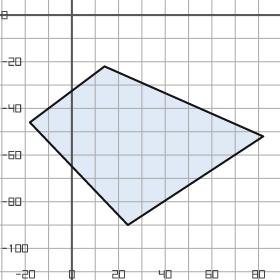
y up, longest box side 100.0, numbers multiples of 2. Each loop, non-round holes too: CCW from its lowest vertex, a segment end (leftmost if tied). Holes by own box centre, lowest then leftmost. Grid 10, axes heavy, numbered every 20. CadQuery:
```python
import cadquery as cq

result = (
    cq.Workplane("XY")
    .moveTo(24.0, -90.0)
    .lineTo(82.0, -52.0)
    .lineTo(14.0, -22.0)
    .lineTo(-18.0, -46.0)
    .close()
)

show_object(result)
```